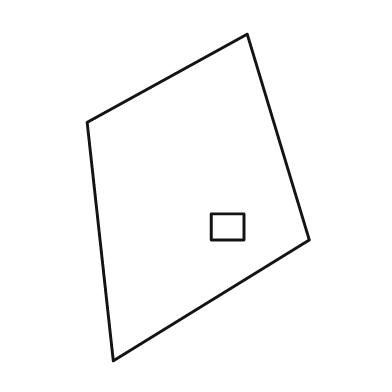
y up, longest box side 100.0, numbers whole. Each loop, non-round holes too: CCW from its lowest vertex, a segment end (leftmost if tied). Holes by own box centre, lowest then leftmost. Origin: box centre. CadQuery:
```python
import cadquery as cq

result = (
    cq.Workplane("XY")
    .moveTo(-26.0, -50.0)
    .lineTo(34.0, -13.0)
    .lineTo(15.0, 50.0)
    .lineTo(-34.0, 23.0)
    .close()
    .moveTo(4.0, -13.0)
    .lineTo(14.0, -13.0)
    .lineTo(14.0, -5.0)
    .lineTo(4.0, -5.0)
    .close()
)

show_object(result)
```